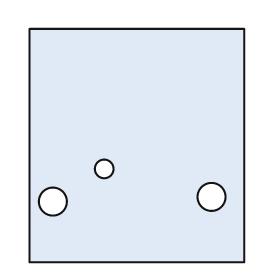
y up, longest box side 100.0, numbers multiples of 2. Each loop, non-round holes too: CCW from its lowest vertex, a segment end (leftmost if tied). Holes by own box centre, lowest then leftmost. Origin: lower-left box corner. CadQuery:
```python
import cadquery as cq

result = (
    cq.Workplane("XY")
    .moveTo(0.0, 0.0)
    .lineTo(92.0, 0.0)
    .lineTo(92.0, 100.0)
    .lineTo(0.0, 100.0)
    .close()
    .moveTo(10.0, 26.0)
    .circle(6.0)
    .moveTo(78.0, 28.0)
    .circle(6.0)
    .moveTo(32.0, 40.0)
    .circle(4.0)
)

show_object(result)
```